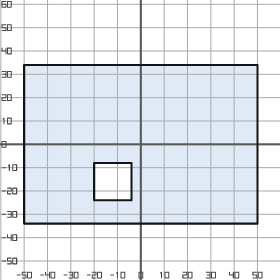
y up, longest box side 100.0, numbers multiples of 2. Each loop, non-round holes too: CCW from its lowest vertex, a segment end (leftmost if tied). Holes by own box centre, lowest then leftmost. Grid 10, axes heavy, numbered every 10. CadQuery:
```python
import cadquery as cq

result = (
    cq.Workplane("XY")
    .moveTo(-50.0, -34.0)
    .lineTo(50.0, -34.0)
    .lineTo(50.0, 34.0)
    .lineTo(-50.0, 34.0)
    .close()
    .moveTo(-20.0, -24.0)
    .lineTo(-4.0, -24.0)
    .lineTo(-4.0, -8.0)
    .lineTo(-20.0, -8.0)
    .close()
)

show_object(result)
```